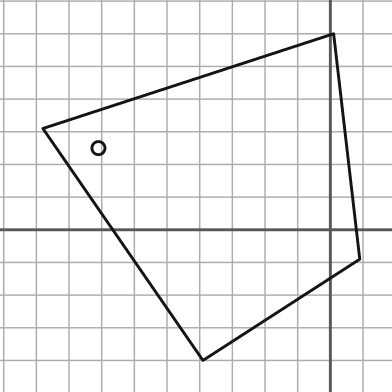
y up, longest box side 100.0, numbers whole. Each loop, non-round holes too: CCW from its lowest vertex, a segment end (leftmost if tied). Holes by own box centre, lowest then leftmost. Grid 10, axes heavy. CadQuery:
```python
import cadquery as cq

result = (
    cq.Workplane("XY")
    .moveTo(-39.0, -40.0)
    .lineTo(9.0, -9.0)
    .lineTo(1.0, 60.0)
    .lineTo(-88.0, 31.0)
    .close()
    .moveTo(-71.0, 25.0)
    .circle(2.0)
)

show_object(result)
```